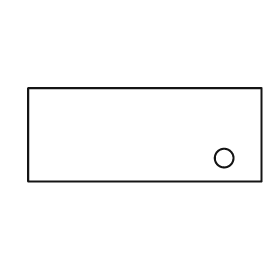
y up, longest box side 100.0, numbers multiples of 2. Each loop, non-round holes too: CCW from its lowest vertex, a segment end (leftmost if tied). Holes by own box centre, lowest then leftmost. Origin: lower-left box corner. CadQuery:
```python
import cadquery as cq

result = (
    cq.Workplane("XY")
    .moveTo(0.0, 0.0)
    .lineTo(100.0, 0.0)
    .lineTo(100.0, 40.0)
    .lineTo(0.0, 40.0)
    .close()
    .moveTo(84.0, 10.0)
    .circle(4.0)
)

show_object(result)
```